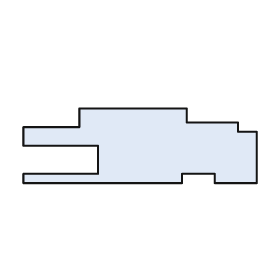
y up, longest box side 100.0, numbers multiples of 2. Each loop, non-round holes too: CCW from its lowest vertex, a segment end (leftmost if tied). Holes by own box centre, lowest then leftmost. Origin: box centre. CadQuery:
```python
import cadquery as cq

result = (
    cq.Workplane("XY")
    .moveTo(-50.0, -16.0)
    .lineTo(18.0, -16.0)
    .lineTo(18.0, -12.0)
    .lineTo(32.0, -12.0)
    .lineTo(32.0, -16.0)
    .lineTo(50.0, -16.0)
    .lineTo(50.0, 6.0)
    .lineTo(42.0, 6.0)
    .lineTo(42.0, 10.0)
    .lineTo(20.0, 10.0)
    .lineTo(20.0, 16.0)
    .lineTo(-26.0, 16.0)
    .lineTo(-26.0, 8.0)
    .lineTo(-50.0, 8.0)
    .lineTo(-50.0, 0.0)
    .lineTo(-18.0, 0.0)
    .lineTo(-18.0, -12.0)
    .lineTo(-50.0, -12.0)
    .close()
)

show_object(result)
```